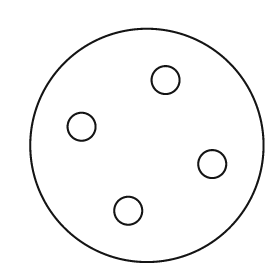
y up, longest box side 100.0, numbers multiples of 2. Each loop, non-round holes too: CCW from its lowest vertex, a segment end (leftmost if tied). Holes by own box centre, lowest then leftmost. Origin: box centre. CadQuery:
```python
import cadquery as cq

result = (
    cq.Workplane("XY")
    .moveTo(0.0, 0.0)
    .circle(50.0)
    .moveTo(-8.0, -28.0)
    .circle(6.0)
    .moveTo(28.0, -8.0)
    .circle(6.0)
    .moveTo(-28.0, 8.0)
    .circle(6.0)
    .moveTo(8.0, 28.0)
    .circle(6.0)
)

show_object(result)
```